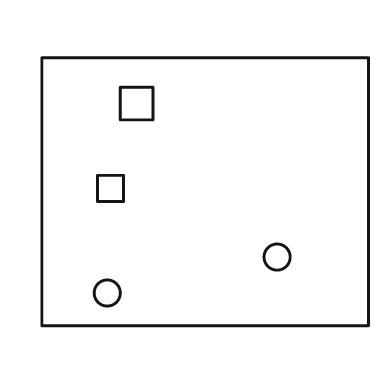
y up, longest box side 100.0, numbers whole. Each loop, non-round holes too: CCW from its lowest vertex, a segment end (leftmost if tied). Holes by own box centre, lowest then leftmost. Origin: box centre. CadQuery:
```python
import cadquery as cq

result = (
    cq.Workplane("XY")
    .moveTo(-50.0, -41.0)
    .lineTo(50.0, -41.0)
    .lineTo(50.0, 41.0)
    .lineTo(-50.0, 41.0)
    .close()
    .moveTo(-30.0, -31.0)
    .circle(4.0)
    .moveTo(22.0, -20.0)
    .circle(4.0)
    .moveTo(-33.0, -3.0)
    .lineTo(-25.0, -3.0)
    .lineTo(-25.0, 5.0)
    .lineTo(-33.0, 5.0)
    .close()
    .moveTo(-26.0, 22.0)
    .lineTo(-16.0, 22.0)
    .lineTo(-16.0, 32.0)
    .lineTo(-26.0, 32.0)
    .close()
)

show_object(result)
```